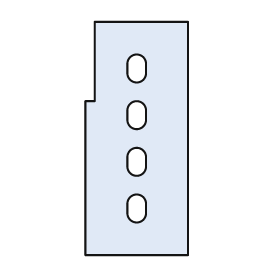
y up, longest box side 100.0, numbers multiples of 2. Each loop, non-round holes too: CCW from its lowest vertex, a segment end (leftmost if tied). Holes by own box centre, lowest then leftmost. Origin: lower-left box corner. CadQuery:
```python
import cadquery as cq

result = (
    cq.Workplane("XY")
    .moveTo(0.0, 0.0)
    .lineTo(44.0, 0.0)
    .lineTo(44.0, 100.0)
    .lineTo(4.0, 100.0)
    .lineTo(4.0, 66.0)
    .lineTo(0.0, 66.0)
    .close()
    .moveTo(18.0, 18.0)
    .threePointArc((22.0, 14.0), (26.0, 18.0))
    .lineTo(26.0, 22.0)
    .threePointArc((22.0, 26.0), (18.0, 22.0))
    .close()
    .moveTo(18.0, 38.0)
    .threePointArc((22.0, 34.0), (26.0, 38.0))
    .lineTo(26.0, 42.0)
    .threePointArc((22.0, 46.0), (18.0, 42.0))
    .close()
    .moveTo(18.0, 58.0)
    .threePointArc((22.0, 54.0), (26.0, 58.0))
    .lineTo(26.0, 62.0)
    .threePointArc((22.0, 66.0), (18.0, 62.0))
    .close()
    .moveTo(18.0, 78.0)
    .threePointArc((22.0, 74.0), (26.0, 78.0))
    .lineTo(26.0, 82.0)
    .threePointArc((22.0, 86.0), (18.0, 82.0))
    .close()
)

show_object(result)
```